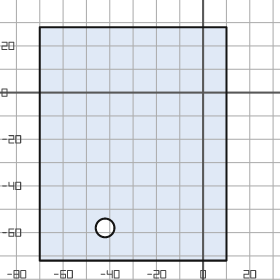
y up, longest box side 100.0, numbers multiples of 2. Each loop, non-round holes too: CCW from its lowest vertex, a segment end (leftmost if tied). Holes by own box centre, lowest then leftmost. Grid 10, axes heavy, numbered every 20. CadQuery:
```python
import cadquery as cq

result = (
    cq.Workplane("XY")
    .moveTo(-70.0, -72.0)
    .lineTo(10.0, -72.0)
    .lineTo(10.0, 28.0)
    .lineTo(-70.0, 28.0)
    .close()
    .moveTo(-42.0, -58.0)
    .circle(4.0)
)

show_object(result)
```